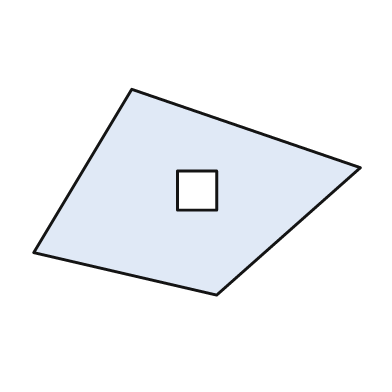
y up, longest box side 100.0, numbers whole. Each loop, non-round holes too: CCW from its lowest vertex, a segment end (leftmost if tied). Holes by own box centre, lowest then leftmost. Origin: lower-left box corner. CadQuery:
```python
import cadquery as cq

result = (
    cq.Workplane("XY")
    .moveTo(56.0, 0.0)
    .lineTo(100.0, 39.0)
    .lineTo(30.0, 63.0)
    .lineTo(0.0, 13.0)
    .close()
    .moveTo(44.0, 26.0)
    .lineTo(56.0, 26.0)
    .lineTo(56.0, 38.0)
    .lineTo(44.0, 38.0)
    .close()
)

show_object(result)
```